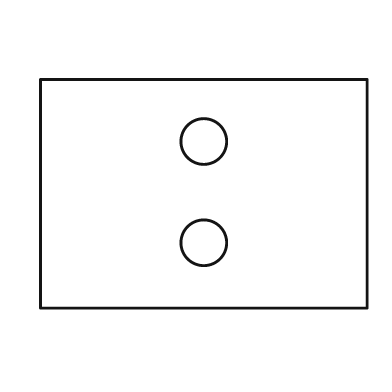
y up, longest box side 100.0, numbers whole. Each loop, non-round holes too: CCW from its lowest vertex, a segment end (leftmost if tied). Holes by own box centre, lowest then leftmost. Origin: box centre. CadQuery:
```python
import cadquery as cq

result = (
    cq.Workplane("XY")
    .moveTo(-50.0, -35.0)
    .lineTo(50.0, -35.0)
    .lineTo(50.0, 35.0)
    .lineTo(-50.0, 35.0)
    .close()
    .moveTo(0.0, -15.0)
    .circle(7.0)
    .moveTo(0.0, 16.0)
    .circle(7.0)
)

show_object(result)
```